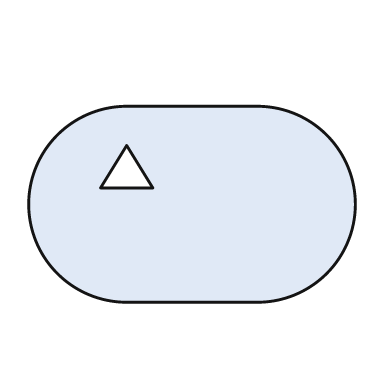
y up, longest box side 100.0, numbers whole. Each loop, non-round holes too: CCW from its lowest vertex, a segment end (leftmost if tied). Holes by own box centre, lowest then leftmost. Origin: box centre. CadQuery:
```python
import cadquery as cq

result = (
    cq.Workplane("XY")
    .moveTo(-20.0, -30.0)
    .lineTo(20.0, -30.0)
    .threePointArc((50.0, 0.0), (20.0, 30.0))
    .lineTo(-20.0, 30.0)
    .threePointArc((-50.0, 0.0), (-20.0, -30.0))
    .close()
    .moveTo(-28.0, 5.0)
    .lineTo(-12.0, 5.0)
    .lineTo(-20.0, 18.0)
    .close()
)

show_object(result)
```